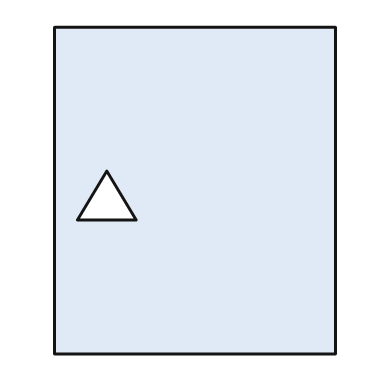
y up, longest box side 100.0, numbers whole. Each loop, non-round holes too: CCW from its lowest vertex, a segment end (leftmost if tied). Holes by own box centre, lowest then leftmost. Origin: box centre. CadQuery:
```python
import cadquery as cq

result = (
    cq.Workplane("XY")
    .moveTo(-43.0, -50.0)
    .lineTo(43.0, -50.0)
    .lineTo(43.0, 50.0)
    .lineTo(-43.0, 50.0)
    .close()
    .moveTo(-36.0, -9.0)
    .lineTo(-18.0, -9.0)
    .lineTo(-27.0, 6.0)
    .close()
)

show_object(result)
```